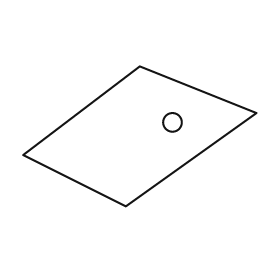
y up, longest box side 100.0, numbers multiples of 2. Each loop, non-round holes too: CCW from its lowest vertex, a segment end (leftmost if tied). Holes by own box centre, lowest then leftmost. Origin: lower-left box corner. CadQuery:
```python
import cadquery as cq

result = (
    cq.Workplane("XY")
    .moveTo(44.0, 0.0)
    .lineTo(100.0, 40.0)
    .lineTo(50.0, 60.0)
    .lineTo(0.0, 22.0)
    .close()
    .moveTo(64.0, 36.0)
    .circle(4.0)
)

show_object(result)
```